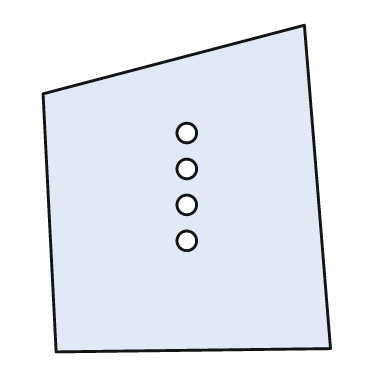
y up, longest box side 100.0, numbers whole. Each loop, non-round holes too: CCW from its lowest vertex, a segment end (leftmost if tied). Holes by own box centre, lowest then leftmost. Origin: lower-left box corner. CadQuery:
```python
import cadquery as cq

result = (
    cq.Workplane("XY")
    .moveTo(4.0, 0.0)
    .lineTo(88.0, 1.0)
    .lineTo(80.0, 100.0)
    .lineTo(0.0, 79.0)
    .close()
    .moveTo(44.0, 34.0)
    .circle(3.0)
    .moveTo(44.0, 45.0)
    .circle(3.0)
    .moveTo(44.0, 56.0)
    .circle(3.0)
    .moveTo(44.0, 67.0)
    .circle(3.0)
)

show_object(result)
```